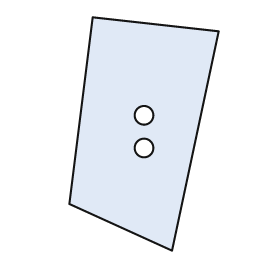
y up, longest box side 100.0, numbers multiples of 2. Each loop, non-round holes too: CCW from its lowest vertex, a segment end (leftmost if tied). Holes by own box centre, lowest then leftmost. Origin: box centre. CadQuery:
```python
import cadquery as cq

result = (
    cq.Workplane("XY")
    .moveTo(12.0, -50.0)
    .lineTo(32.0, 44.0)
    .lineTo(-22.0, 50.0)
    .lineTo(-32.0, -30.0)
    .close()
    .moveTo(0.0, -6.0)
    .circle(4.0)
    .moveTo(0.0, 8.0)
    .circle(4.0)
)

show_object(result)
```